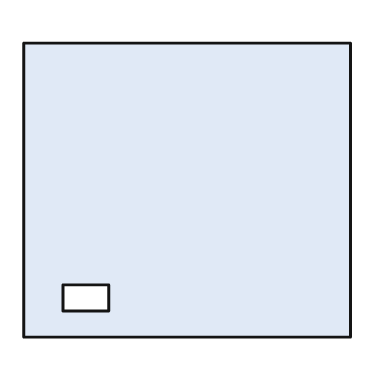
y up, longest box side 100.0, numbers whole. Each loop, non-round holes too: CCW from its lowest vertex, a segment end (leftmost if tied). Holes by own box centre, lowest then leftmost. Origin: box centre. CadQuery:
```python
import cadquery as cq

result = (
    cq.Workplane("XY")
    .moveTo(-50.0, -45.0)
    .lineTo(50.0, -45.0)
    .lineTo(50.0, 45.0)
    .lineTo(-50.0, 45.0)
    .close()
    .moveTo(-38.0, -37.0)
    .lineTo(-24.0, -37.0)
    .lineTo(-24.0, -29.0)
    .lineTo(-38.0, -29.0)
    .close()
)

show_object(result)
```